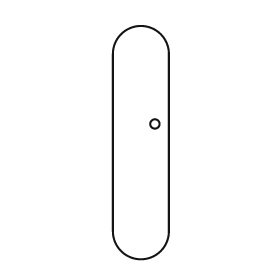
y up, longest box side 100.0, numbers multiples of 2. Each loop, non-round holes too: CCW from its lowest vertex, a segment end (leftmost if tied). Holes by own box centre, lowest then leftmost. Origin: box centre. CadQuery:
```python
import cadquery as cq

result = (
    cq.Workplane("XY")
    .moveTo(-12.0, -38.0)
    .threePointArc((0.0, -50.0), (12.0, -38.0))
    .lineTo(12.0, 38.0)
    .threePointArc((0.0, 50.0), (-12.0, 38.0))
    .close()
    .moveTo(6.0, 8.0)
    .circle(2.0)
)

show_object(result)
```